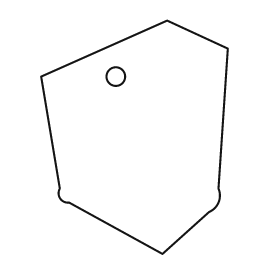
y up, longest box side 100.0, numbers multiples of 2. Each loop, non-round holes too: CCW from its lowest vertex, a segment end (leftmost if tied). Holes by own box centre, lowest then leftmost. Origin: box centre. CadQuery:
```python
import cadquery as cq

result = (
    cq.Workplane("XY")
    .moveTo(12.0, -50.0)
    .lineTo(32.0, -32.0)
    .threePointArc((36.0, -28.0), (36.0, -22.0))
    .lineTo(40.0, 38.0)
    .lineTo(14.0, 50.0)
    .lineTo(-40.0, 26.0)
    .lineTo(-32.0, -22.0)
    .threePointArc((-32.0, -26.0), (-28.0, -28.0))
    .close()
    .moveTo(-8.0, 26.0)
    .circle(4.0)
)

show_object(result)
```